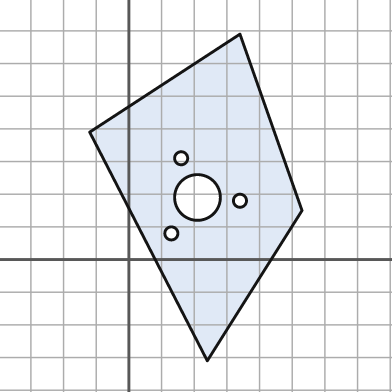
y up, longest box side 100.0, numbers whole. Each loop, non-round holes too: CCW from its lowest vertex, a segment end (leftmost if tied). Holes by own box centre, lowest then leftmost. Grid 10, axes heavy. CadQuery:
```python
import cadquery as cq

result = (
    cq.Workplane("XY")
    .moveTo(24.0, -31.0)
    .lineTo(53.0, 15.0)
    .lineTo(34.0, 69.0)
    .lineTo(-12.0, 39.0)
    .close()
    .moveTo(13.0, 8.0)
    .circle(2.0)
    .moveTo(34.0, 18.0)
    .circle(2.0)
    .moveTo(21.0, 19.0)
    .circle(7.0)
    .moveTo(16.0, 31.0)
    .circle(2.0)
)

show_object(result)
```